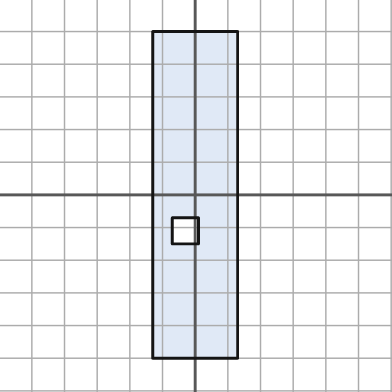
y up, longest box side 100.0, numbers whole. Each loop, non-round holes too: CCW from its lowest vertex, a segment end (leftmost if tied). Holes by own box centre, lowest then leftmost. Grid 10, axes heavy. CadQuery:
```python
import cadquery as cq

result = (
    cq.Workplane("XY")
    .moveTo(-13.0, -50.0)
    .lineTo(13.0, -50.0)
    .lineTo(13.0, 50.0)
    .lineTo(-13.0, 50.0)
    .close()
    .moveTo(-7.0, -15.0)
    .lineTo(1.0, -15.0)
    .lineTo(1.0, -7.0)
    .lineTo(-7.0, -7.0)
    .close()
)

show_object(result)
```